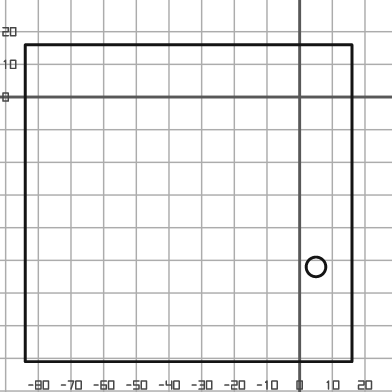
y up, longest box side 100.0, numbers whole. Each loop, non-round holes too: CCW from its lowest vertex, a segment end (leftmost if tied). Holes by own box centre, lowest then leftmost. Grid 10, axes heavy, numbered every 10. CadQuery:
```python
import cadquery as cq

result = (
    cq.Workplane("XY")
    .moveTo(-84.0, -81.0)
    .lineTo(16.0, -81.0)
    .lineTo(16.0, 16.0)
    .lineTo(-84.0, 16.0)
    .close()
    .moveTo(5.0, -52.0)
    .circle(3.0)
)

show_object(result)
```